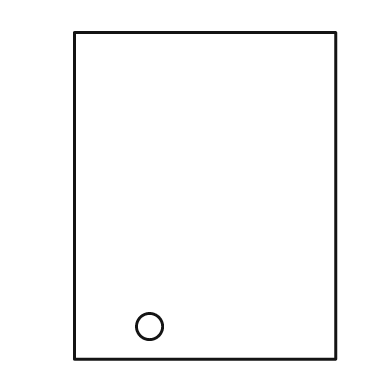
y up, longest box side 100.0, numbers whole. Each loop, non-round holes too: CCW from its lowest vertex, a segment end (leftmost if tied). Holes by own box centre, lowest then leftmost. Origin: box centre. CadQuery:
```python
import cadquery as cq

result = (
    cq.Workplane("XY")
    .moveTo(-40.0, -50.0)
    .lineTo(40.0, -50.0)
    .lineTo(40.0, 50.0)
    .lineTo(-40.0, 50.0)
    .close()
    .moveTo(-17.0, -40.0)
    .circle(4.0)
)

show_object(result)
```